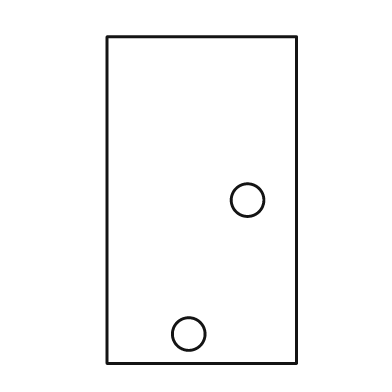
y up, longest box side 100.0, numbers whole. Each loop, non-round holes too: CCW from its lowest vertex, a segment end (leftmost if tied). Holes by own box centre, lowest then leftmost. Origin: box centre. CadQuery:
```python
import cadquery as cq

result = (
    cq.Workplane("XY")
    .moveTo(-29.0, -50.0)
    .lineTo(29.0, -50.0)
    .lineTo(29.0, 50.0)
    .lineTo(-29.0, 50.0)
    .close()
    .moveTo(-4.0, -41.0)
    .circle(5.0)
    .moveTo(14.0, 0.0)
    .circle(5.0)
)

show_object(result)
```